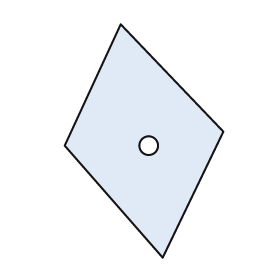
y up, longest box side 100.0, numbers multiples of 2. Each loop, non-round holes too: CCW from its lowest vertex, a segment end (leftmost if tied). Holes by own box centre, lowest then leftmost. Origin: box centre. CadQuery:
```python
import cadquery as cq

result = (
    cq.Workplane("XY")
    .moveTo(8.0, -50.0)
    .lineTo(34.0, 4.0)
    .lineTo(-10.0, 50.0)
    .lineTo(-34.0, -2.0)
    .close()
    .moveTo(2.0, -2.0)
    .circle(4.0)
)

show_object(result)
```